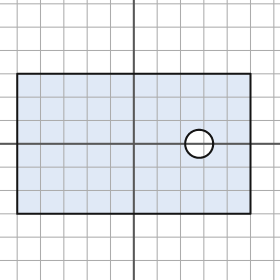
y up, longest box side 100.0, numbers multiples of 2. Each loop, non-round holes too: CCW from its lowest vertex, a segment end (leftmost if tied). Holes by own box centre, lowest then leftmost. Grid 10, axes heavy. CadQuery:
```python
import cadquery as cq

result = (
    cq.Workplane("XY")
    .moveTo(-50.0, -30.0)
    .lineTo(50.0, -30.0)
    .lineTo(50.0, 30.0)
    .lineTo(-50.0, 30.0)
    .close()
    .moveTo(28.0, 0.0)
    .circle(6.0)
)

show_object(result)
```